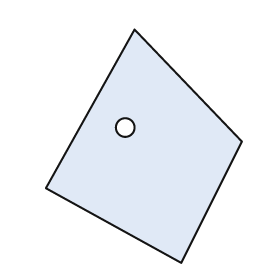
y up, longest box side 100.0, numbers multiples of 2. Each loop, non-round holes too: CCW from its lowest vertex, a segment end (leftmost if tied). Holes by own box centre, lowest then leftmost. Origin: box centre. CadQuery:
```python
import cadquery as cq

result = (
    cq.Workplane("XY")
    .moveTo(16.0, -50.0)
    .lineTo(42.0, 2.0)
    .lineTo(-4.0, 50.0)
    .lineTo(-42.0, -18.0)
    .close()
    .moveTo(-8.0, 8.0)
    .circle(4.0)
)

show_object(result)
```